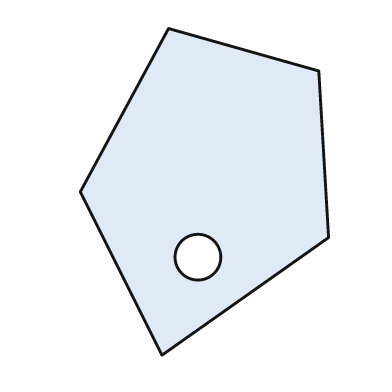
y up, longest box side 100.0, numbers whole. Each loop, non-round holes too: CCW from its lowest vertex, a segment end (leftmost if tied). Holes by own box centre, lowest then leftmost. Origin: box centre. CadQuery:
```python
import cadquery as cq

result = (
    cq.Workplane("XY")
    .moveTo(-13.0, -50.0)
    .lineTo(38.0, -14.0)
    .lineTo(35.0, 37.0)
    .lineTo(-11.0, 50.0)
    .lineTo(-38.0, 0.0)
    .close()
    .moveTo(-2.0, -20.0)
    .circle(7.0)
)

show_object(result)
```